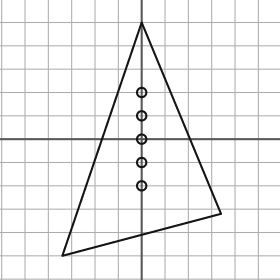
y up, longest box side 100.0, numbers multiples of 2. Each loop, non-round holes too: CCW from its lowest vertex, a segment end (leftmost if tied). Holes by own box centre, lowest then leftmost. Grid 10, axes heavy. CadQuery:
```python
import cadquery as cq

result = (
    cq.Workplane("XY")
    .moveTo(-34.0, -50.0)
    .lineTo(34.0, -32.0)
    .lineTo(0.0, 50.0)
    .close()
    .moveTo(0.0, -20.0)
    .circle(2.0)
    .moveTo(0.0, -10.0)
    .circle(2.0)
    .moveTo(0.0, 0.0)
    .circle(2.0)
    .moveTo(0.0, 10.0)
    .circle(2.0)
    .moveTo(0.0, 20.0)
    .circle(2.0)
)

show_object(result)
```